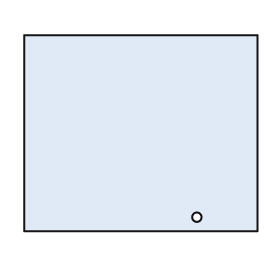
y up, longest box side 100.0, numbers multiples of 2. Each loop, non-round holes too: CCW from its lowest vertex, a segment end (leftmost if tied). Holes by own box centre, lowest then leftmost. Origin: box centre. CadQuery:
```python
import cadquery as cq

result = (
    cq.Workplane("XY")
    .moveTo(-50.0, -42.0)
    .lineTo(50.0, -42.0)
    .lineTo(50.0, 42.0)
    .lineTo(-50.0, 42.0)
    .close()
    .moveTo(24.0, -36.0)
    .circle(2.0)
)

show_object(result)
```